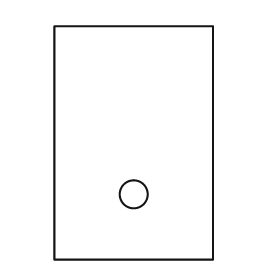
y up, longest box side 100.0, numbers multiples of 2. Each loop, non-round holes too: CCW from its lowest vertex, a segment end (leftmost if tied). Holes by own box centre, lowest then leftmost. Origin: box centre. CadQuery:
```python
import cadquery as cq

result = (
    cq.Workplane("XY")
    .moveTo(-34.0, -50.0)
    .lineTo(34.0, -50.0)
    .lineTo(34.0, 50.0)
    .lineTo(-34.0, 50.0)
    .close()
    .moveTo(0.0, -22.0)
    .circle(6.0)
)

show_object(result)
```